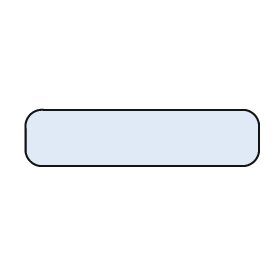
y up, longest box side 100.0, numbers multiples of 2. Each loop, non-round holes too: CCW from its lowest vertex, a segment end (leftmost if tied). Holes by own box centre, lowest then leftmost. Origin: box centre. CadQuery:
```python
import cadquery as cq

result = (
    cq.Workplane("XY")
    .moveTo(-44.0, -12.0)
    .lineTo(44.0, -12.0)
    .threePointArc((48.0, -10.0), (50.0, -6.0))
    .lineTo(50.0, 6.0)
    .threePointArc((48.0, 10.0), (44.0, 12.0))
    .lineTo(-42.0, 12.0)
    .threePointArc((-48.0, 10.0), (-50.0, 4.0))
    .lineTo(-50.0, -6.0)
    .threePointArc((-48.0, -10.0), (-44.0, -12.0))
    .close()
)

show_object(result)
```